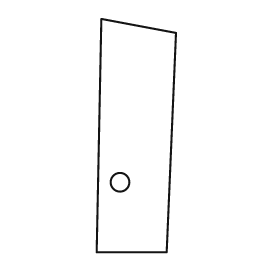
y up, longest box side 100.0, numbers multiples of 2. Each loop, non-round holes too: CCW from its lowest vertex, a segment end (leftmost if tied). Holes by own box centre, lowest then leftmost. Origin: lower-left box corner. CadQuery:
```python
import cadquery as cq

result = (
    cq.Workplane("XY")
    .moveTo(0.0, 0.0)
    .lineTo(30.0, 0.0)
    .lineTo(34.0, 94.0)
    .lineTo(2.0, 100.0)
    .close()
    .moveTo(10.0, 30.0)
    .circle(4.0)
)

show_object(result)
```